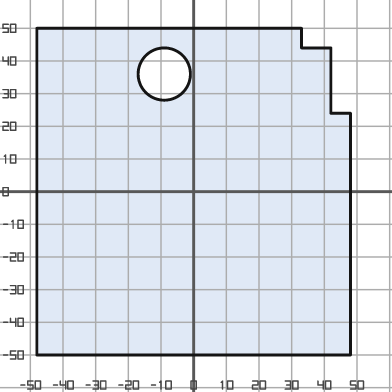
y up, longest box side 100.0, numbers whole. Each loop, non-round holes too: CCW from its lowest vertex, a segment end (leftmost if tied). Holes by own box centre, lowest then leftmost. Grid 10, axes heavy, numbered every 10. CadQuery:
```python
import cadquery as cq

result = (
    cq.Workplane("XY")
    .moveTo(-48.0, -50.0)
    .lineTo(48.0, -50.0)
    .lineTo(48.0, 24.0)
    .lineTo(42.0, 24.0)
    .lineTo(42.0, 44.0)
    .lineTo(33.0, 44.0)
    .lineTo(33.0, 50.0)
    .lineTo(-48.0, 50.0)
    .close()
    .moveTo(-9.0, 36.0)
    .circle(8.0)
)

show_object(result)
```